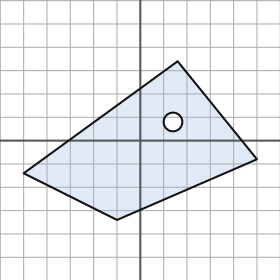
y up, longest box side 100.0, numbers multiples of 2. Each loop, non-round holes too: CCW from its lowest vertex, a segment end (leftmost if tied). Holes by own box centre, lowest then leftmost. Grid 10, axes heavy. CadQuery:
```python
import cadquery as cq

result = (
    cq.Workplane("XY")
    .moveTo(-10.0, -34.0)
    .lineTo(50.0, -8.0)
    .lineTo(16.0, 34.0)
    .lineTo(-50.0, -14.0)
    .close()
    .moveTo(14.0, 8.0)
    .circle(4.0)
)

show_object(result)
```